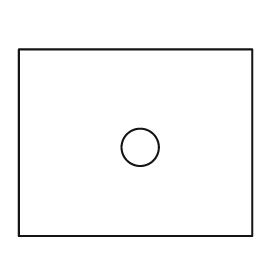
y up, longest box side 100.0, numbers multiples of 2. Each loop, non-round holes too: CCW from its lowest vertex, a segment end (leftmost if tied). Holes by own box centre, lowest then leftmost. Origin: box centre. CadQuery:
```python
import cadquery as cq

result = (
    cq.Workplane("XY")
    .moveTo(-50.0, -40.0)
    .lineTo(50.0, -40.0)
    .lineTo(50.0, 40.0)
    .lineTo(-50.0, 40.0)
    .close()
    .moveTo(2.0, -2.0)
    .circle(8.0)
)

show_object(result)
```